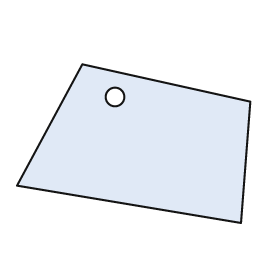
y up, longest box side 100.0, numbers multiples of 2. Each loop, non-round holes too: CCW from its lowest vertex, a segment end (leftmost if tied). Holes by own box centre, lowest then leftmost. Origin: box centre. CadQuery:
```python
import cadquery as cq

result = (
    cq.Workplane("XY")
    .moveTo(46.0, -34.0)
    .lineTo(50.0, 18.0)
    .lineTo(-22.0, 34.0)
    .lineTo(-50.0, -18.0)
    .close()
    .moveTo(-8.0, 20.0)
    .circle(4.0)
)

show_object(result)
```